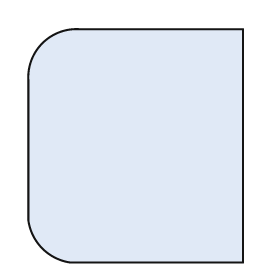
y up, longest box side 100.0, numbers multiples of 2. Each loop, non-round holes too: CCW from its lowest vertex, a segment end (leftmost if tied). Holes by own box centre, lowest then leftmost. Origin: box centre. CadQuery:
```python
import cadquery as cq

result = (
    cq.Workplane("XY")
    .moveTo(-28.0, -50.0)
    .lineTo(46.0, -50.0)
    .lineTo(46.0, 50.0)
    .lineTo(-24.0, 50.0)
    .threePointArc((-40.0, 44.0), (-46.0, 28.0))
    .lineTo(-46.0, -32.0)
    .threePointArc((-40.0, -44.0), (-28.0, -50.0))
    .close()
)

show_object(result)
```